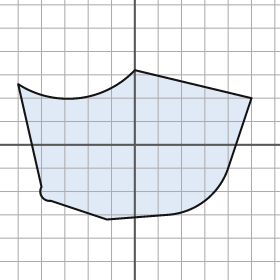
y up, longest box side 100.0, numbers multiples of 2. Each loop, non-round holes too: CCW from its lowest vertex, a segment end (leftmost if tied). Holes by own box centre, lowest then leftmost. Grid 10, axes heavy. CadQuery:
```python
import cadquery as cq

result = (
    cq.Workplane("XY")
    .moveTo(-12.0, -32.0)
    .lineTo(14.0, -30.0)
    .threePointArc((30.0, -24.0), (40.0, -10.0))
    .lineTo(50.0, 20.0)
    .lineTo(0.0, 32.0)
    .threePointArc((-24.0, 20.0), (-50.0, 26.0))
    .lineTo(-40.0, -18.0)
    .threePointArc((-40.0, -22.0), (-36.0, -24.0))
    .close()
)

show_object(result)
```